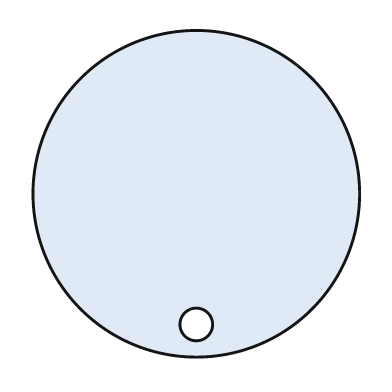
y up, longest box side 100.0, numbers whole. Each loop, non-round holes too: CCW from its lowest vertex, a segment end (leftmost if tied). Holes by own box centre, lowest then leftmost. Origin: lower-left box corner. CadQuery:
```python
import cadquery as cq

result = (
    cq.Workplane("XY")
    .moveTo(50.0, 50.0)
    .circle(50.0)
    .moveTo(50.0, 10.0)
    .circle(5.0)
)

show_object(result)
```